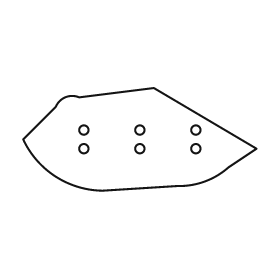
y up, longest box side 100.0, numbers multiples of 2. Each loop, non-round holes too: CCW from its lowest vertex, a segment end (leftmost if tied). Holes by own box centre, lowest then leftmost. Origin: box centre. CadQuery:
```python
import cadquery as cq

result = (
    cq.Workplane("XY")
    .moveTo(-16.0, -22.0)
    .lineTo(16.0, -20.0)
    .threePointArc((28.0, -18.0), (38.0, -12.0))
    .lineTo(50.0, -4.0)
    .lineTo(6.0, 22.0)
    .lineTo(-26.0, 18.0)
    .threePointArc((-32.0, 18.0), (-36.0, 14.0))
    .lineTo(-50.0, 0.0)
    .threePointArc((-36.0, -16.0), (-16.0, -22.0))
    .close()
    .moveTo(-24.0, -4.0)
    .circle(2.0)
    .moveTo(0.0, -4.0)
    .circle(2.0)
    .moveTo(24.0, -4.0)
    .circle(2.0)
    .moveTo(-24.0, 4.0)
    .circle(2.0)
    .moveTo(0.0, 4.0)
    .circle(2.0)
    .moveTo(24.0, 4.0)
    .circle(2.0)
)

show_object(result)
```